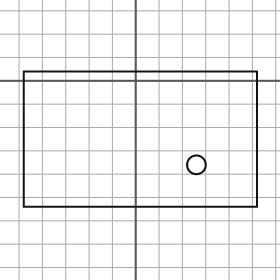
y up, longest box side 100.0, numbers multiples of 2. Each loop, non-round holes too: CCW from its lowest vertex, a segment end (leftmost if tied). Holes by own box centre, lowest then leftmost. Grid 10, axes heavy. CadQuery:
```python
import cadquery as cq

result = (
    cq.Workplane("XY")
    .moveTo(-48.0, -54.0)
    .lineTo(52.0, -54.0)
    .lineTo(52.0, 4.0)
    .lineTo(-48.0, 4.0)
    .close()
    .moveTo(26.0, -36.0)
    .circle(4.0)
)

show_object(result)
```